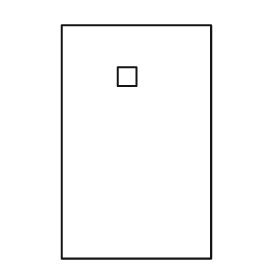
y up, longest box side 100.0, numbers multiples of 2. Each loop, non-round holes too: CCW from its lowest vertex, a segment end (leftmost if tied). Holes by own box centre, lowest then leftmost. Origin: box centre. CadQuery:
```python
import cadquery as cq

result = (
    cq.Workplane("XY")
    .moveTo(-32.0, -50.0)
    .lineTo(32.0, -50.0)
    .lineTo(32.0, 50.0)
    .lineTo(-32.0, 50.0)
    .close()
    .moveTo(-8.0, 24.0)
    .lineTo(0.0, 24.0)
    .lineTo(0.0, 32.0)
    .lineTo(-8.0, 32.0)
    .close()
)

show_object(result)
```